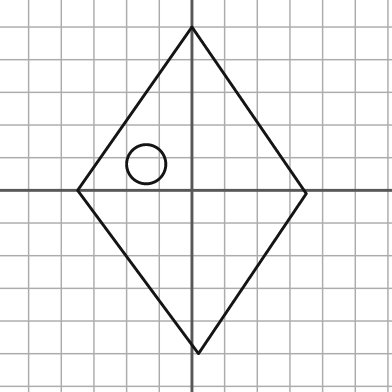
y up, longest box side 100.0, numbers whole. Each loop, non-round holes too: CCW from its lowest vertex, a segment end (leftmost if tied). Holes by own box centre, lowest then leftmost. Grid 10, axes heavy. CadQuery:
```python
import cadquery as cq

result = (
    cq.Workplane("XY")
    .moveTo(2.0, -50.0)
    .lineTo(35.0, -1.0)
    .lineTo(0.0, 50.0)
    .lineTo(-35.0, 0.0)
    .close()
    .moveTo(-14.0, 8.0)
    .circle(6.0)
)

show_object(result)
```